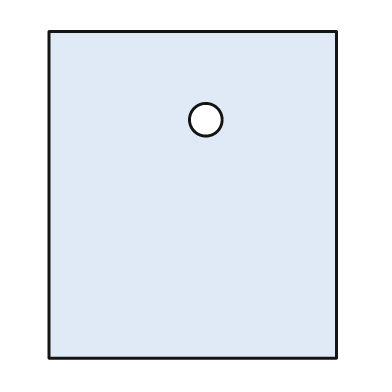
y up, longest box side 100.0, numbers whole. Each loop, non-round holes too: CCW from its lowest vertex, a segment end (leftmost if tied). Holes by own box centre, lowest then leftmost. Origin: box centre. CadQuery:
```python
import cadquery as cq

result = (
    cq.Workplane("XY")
    .moveTo(-44.0, -50.0)
    .lineTo(44.0, -50.0)
    .lineTo(44.0, 50.0)
    .lineTo(-44.0, 50.0)
    .close()
    .moveTo(4.0, 23.0)
    .circle(5.0)
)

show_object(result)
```